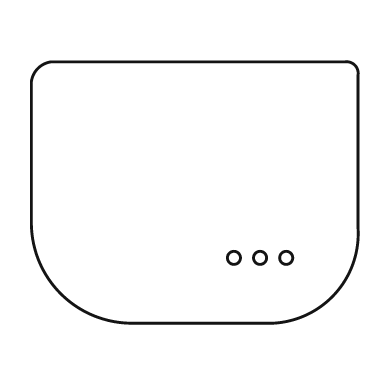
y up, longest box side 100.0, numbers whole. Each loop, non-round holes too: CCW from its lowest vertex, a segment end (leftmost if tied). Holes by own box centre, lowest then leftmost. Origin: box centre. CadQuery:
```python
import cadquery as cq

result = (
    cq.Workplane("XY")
    .moveTo(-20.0, -40.0)
    .lineTo(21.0, -40.0)
    .threePointArc((42.0, -32.0), (50.0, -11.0))
    .lineTo(50.0, 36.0)
    .threePointArc((49.0, 39.0), (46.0, 40.0))
    .lineTo(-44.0, 40.0)
    .threePointArc((-48.0, 38.0), (-50.0, 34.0))
    .lineTo(-50.0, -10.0)
    .threePointArc((-41.0, -31.0), (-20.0, -40.0))
    .close()
    .moveTo(12.0, -20.0)
    .circle(2.0)
    .moveTo(20.0, -20.0)
    .circle(2.0)
    .moveTo(28.0, -20.0)
    .circle(2.0)
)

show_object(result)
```